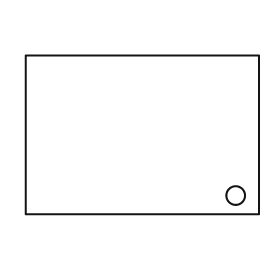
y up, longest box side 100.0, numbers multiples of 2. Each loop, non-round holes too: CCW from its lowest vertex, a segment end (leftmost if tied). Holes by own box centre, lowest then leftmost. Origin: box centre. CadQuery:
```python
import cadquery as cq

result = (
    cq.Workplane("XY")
    .moveTo(-50.0, -34.0)
    .lineTo(50.0, -34.0)
    .lineTo(50.0, 34.0)
    .lineTo(-50.0, 34.0)
    .close()
    .moveTo(40.0, -26.0)
    .circle(4.0)
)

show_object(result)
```